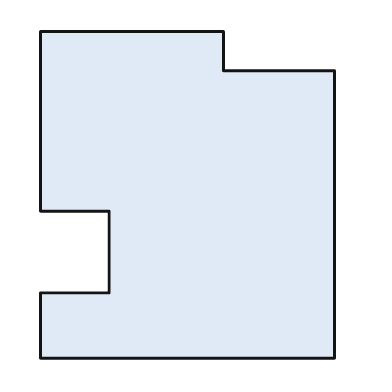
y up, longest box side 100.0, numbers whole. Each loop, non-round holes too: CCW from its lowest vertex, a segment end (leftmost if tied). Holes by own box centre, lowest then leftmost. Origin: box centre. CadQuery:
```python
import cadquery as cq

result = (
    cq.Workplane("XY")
    .moveTo(-45.0, -50.0)
    .lineTo(45.0, -50.0)
    .lineTo(45.0, 38.0)
    .lineTo(11.0, 38.0)
    .lineTo(11.0, 50.0)
    .lineTo(-45.0, 50.0)
    .lineTo(-45.0, -5.0)
    .lineTo(-24.0, -5.0)
    .lineTo(-24.0, -30.0)
    .lineTo(-45.0, -30.0)
    .close()
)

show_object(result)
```